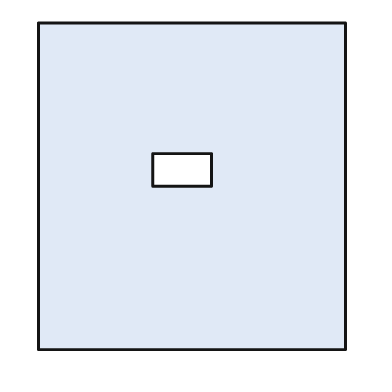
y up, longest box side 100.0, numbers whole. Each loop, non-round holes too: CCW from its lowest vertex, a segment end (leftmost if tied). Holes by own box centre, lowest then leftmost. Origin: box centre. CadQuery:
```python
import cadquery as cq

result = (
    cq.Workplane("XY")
    .moveTo(-47.0, -50.0)
    .lineTo(47.0, -50.0)
    .lineTo(47.0, 50.0)
    .lineTo(-47.0, 50.0)
    .close()
    .moveTo(-12.0, 0.0)
    .lineTo(6.0, 0.0)
    .lineTo(6.0, 10.0)
    .lineTo(-12.0, 10.0)
    .close()
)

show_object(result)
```